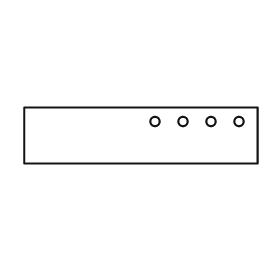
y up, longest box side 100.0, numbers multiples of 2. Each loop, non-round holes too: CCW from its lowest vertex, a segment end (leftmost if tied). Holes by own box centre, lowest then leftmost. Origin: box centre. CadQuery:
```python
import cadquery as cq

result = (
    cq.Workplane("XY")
    .moveTo(-50.0, -12.0)
    .lineTo(50.0, -12.0)
    .lineTo(50.0, 12.0)
    .lineTo(-50.0, 12.0)
    .close()
    .moveTo(6.0, 6.0)
    .circle(2.0)
    .moveTo(18.0, 6.0)
    .circle(2.0)
    .moveTo(30.0, 6.0)
    .circle(2.0)
    .moveTo(42.0, 6.0)
    .circle(2.0)
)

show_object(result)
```